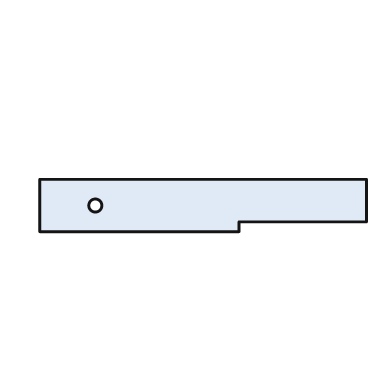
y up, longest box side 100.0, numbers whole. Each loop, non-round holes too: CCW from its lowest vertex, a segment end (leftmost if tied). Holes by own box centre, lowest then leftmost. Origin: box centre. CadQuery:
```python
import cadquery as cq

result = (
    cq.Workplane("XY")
    .moveTo(-50.0, -8.0)
    .lineTo(11.0, -8.0)
    .lineTo(11.0, -5.0)
    .lineTo(50.0, -5.0)
    .lineTo(50.0, 8.0)
    .lineTo(-50.0, 8.0)
    .close()
    .moveTo(-33.0, 0.0)
    .circle(2.0)
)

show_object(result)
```